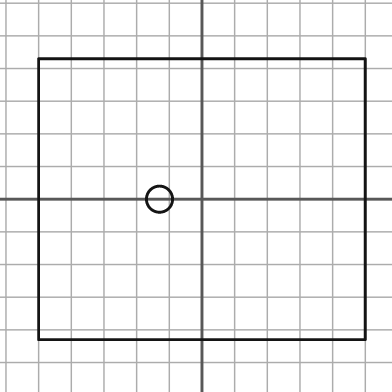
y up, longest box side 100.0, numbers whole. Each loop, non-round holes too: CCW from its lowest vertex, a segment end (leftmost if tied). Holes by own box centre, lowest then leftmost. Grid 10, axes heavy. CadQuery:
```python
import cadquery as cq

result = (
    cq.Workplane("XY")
    .moveTo(-50.0, -43.0)
    .lineTo(50.0, -43.0)
    .lineTo(50.0, 43.0)
    .lineTo(-50.0, 43.0)
    .close()
    .moveTo(-13.0, 0.0)
    .circle(4.0)
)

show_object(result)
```